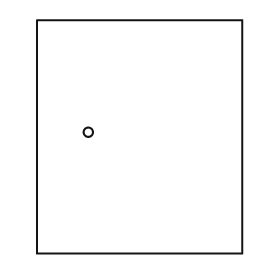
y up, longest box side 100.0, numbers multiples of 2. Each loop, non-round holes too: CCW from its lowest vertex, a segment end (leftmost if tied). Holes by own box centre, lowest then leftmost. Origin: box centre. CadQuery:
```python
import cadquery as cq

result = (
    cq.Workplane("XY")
    .moveTo(-44.0, -50.0)
    .lineTo(44.0, -50.0)
    .lineTo(44.0, 50.0)
    .lineTo(-44.0, 50.0)
    .close()
    .moveTo(-22.0, 2.0)
    .circle(2.0)
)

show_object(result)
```